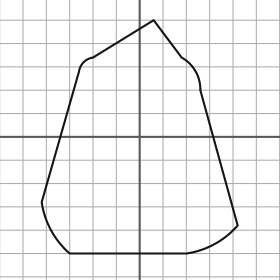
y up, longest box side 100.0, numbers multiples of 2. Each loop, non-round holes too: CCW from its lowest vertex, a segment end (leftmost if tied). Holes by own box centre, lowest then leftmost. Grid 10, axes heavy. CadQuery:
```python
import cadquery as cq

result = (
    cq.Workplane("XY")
    .moveTo(-30.0, -50.0)
    .lineTo(20.0, -50.0)
    .threePointArc((32.0, -46.0), (42.0, -38.0))
    .lineTo(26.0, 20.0)
    .threePointArc((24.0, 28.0), (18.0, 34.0))
    .lineTo(6.0, 50.0)
    .lineTo(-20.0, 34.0)
    .threePointArc((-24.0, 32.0), (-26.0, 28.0))
    .lineTo(-42.0, -28.0)
    .threePointArc((-38.0, -40.0), (-30.0, -50.0))
    .close()
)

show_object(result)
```